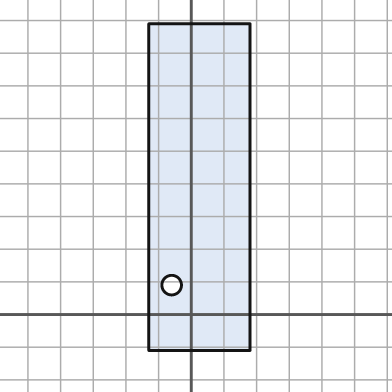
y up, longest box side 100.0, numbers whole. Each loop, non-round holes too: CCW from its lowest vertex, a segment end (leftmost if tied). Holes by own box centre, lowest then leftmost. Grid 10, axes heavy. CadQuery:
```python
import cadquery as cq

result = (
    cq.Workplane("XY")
    .moveTo(-13.0, -11.0)
    .lineTo(18.0, -11.0)
    .lineTo(18.0, 89.0)
    .lineTo(-13.0, 89.0)
    .close()
    .moveTo(-6.0, 9.0)
    .circle(3.0)
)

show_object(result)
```